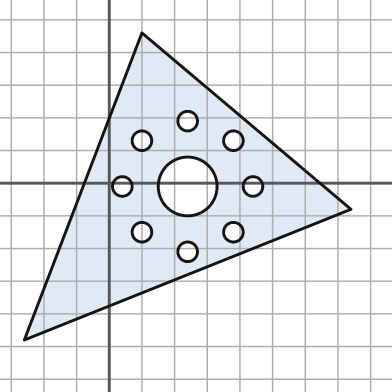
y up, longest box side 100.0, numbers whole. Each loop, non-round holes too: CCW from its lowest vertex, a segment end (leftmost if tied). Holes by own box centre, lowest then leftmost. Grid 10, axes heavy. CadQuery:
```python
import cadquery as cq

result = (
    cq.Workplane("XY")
    .moveTo(-26.0, -48.0)
    .lineTo(74.0, -8.0)
    .lineTo(10.0, 46.0)
    .close()
    .moveTo(24.0, -21.0)
    .circle(3.0)
    .moveTo(10.0, -15.0)
    .circle(3.0)
    .moveTo(38.0, -15.0)
    .circle(3.0)
    .moveTo(4.0, -1.0)
    .circle(3.0)
    .moveTo(24.0, -1.0)
    .circle(9.0)
    .moveTo(44.0, -1.0)
    .circle(3.0)
    .moveTo(10.0, 13.0)
    .circle(3.0)
    .moveTo(38.0, 13.0)
    .circle(3.0)
    .moveTo(24.0, 19.0)
    .circle(3.0)
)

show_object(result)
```